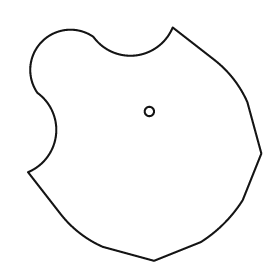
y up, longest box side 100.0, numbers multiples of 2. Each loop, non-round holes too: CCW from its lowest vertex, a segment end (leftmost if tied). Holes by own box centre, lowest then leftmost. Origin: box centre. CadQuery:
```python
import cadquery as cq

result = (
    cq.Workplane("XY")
    .moveTo(4.0, -50.0)
    .lineTo(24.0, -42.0)
    .threePointArc((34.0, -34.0), (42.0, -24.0))
    .lineTo(50.0, -4.0)
    .lineTo(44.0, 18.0)
    .threePointArc((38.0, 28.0), (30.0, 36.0))
    .lineTo(12.0, 50.0)
    .threePointArc((-4.0, 38.0), (-22.0, 46.0))
    .threePointArc((-44.0, 44.0), (-46.0, 22.0))
    .threePointArc((-38.0, 4.0), (-50.0, -12.0))
    .lineTo(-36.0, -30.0)
    .threePointArc((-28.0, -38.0), (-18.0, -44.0))
    .close()
    .moveTo(2.0, 14.0)
    .circle(2.0)
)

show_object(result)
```